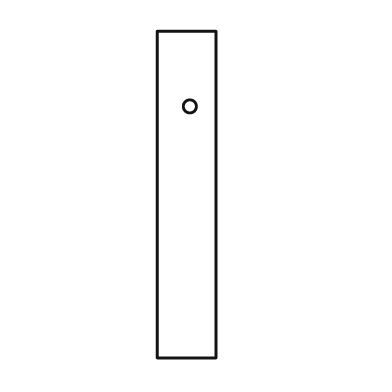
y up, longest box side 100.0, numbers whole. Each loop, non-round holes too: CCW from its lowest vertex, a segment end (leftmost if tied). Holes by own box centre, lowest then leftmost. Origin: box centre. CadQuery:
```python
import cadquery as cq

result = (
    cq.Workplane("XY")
    .moveTo(-9.0, -50.0)
    .lineTo(9.0, -50.0)
    .lineTo(9.0, 50.0)
    .lineTo(-9.0, 50.0)
    .close()
    .moveTo(1.0, 27.0)
    .circle(2.0)
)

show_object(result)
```